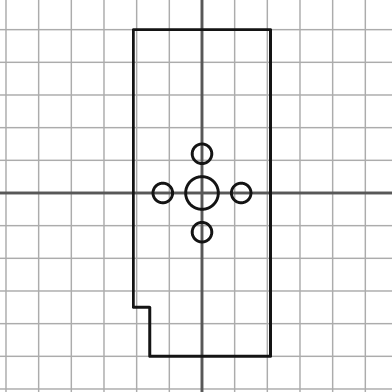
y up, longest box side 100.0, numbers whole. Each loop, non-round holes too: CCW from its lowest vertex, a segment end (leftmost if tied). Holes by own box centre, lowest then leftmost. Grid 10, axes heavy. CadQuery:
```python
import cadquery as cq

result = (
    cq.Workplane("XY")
    .moveTo(-16.0, -50.0)
    .lineTo(21.0, -50.0)
    .lineTo(21.0, 50.0)
    .lineTo(-21.0, 50.0)
    .lineTo(-21.0, -35.0)
    .lineTo(-16.0, -35.0)
    .close()
    .moveTo(0.0, -12.0)
    .circle(3.0)
    .moveTo(-12.0, 0.0)
    .circle(3.0)
    .moveTo(0.0, 0.0)
    .circle(5.0)
    .moveTo(12.0, 0.0)
    .circle(3.0)
    .moveTo(0.0, 12.0)
    .circle(3.0)
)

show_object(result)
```